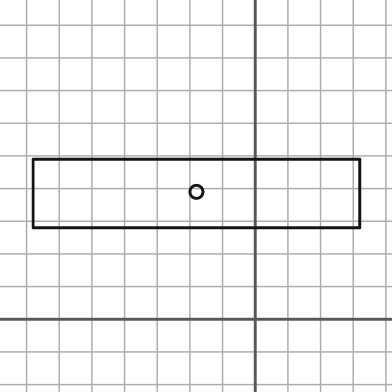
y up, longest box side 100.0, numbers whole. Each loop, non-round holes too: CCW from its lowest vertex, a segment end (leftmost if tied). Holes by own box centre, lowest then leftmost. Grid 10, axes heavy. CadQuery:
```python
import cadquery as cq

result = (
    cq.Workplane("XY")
    .moveTo(-68.0, 28.0)
    .lineTo(32.0, 28.0)
    .lineTo(32.0, 49.0)
    .lineTo(-68.0, 49.0)
    .close()
    .moveTo(-18.0, 39.0)
    .circle(2.0)
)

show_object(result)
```